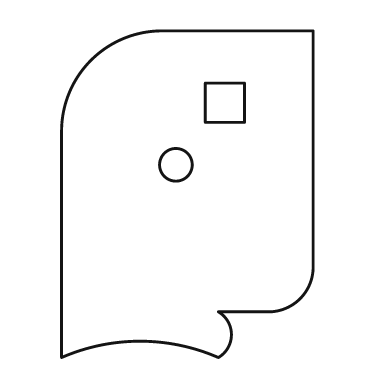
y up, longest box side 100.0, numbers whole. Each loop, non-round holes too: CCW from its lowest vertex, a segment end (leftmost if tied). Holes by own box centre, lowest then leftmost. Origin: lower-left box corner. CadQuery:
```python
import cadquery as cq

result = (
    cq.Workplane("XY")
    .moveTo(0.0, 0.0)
    .threePointArc((24.0, 5.0), (48.0, 0.0))
    .threePointArc((52.0, 7.0), (48.0, 14.0))
    .lineTo(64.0, 14.0)
    .threePointArc((73.0, 18.0), (77.0, 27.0))
    .lineTo(77.0, 100.0)
    .lineTo(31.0, 100.0)
    .threePointArc((9.0, 91.0), (0.0, 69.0))
    .close()
    .moveTo(35.0, 59.0)
    .circle(5.0)
    .moveTo(44.0, 72.0)
    .lineTo(56.0, 72.0)
    .lineTo(56.0, 84.0)
    .lineTo(44.0, 84.0)
    .close()
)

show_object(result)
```